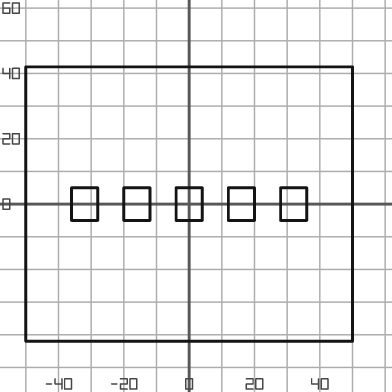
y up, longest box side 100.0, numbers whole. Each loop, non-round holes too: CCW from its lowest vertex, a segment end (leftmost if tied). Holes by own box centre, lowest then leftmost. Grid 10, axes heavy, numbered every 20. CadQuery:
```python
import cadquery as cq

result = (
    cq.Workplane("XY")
    .moveTo(-50.0, -42.0)
    .lineTo(50.0, -42.0)
    .lineTo(50.0, 42.0)
    .lineTo(-50.0, 42.0)
    .close()
    .moveTo(-36.0, -5.0)
    .lineTo(-28.0, -5.0)
    .lineTo(-28.0, 5.0)
    .lineTo(-36.0, 5.0)
    .close()
    .moveTo(-20.0, -5.0)
    .lineTo(-12.0, -5.0)
    .lineTo(-12.0, 5.0)
    .lineTo(-20.0, 5.0)
    .close()
    .moveTo(-4.0, -5.0)
    .lineTo(4.0, -5.0)
    .lineTo(4.0, 5.0)
    .lineTo(-4.0, 5.0)
    .close()
    .moveTo(12.0, -5.0)
    .lineTo(20.0, -5.0)
    .lineTo(20.0, 5.0)
    .lineTo(12.0, 5.0)
    .close()
    .moveTo(28.0, -5.0)
    .lineTo(36.0, -5.0)
    .lineTo(36.0, 5.0)
    .lineTo(28.0, 5.0)
    .close()
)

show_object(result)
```